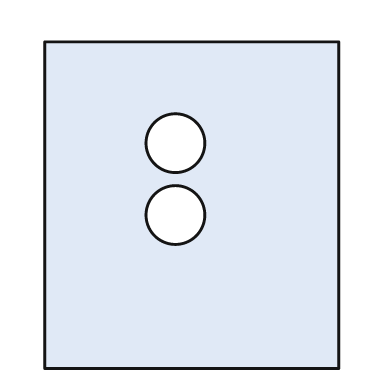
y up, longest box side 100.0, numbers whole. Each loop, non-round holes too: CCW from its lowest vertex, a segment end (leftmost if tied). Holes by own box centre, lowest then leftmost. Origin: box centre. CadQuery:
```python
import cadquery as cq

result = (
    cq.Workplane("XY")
    .moveTo(-45.0, -50.0)
    .lineTo(45.0, -50.0)
    .lineTo(45.0, 50.0)
    .lineTo(-45.0, 50.0)
    .close()
    .moveTo(-5.0, -3.0)
    .circle(9.0)
    .moveTo(-5.0, 19.0)
    .circle(9.0)
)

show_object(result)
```